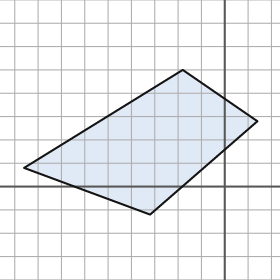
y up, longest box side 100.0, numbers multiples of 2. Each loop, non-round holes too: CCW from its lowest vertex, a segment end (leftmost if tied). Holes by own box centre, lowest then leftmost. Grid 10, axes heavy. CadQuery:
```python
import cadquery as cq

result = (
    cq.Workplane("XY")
    .moveTo(-32.0, -12.0)
    .lineTo(14.0, 28.0)
    .lineTo(-18.0, 50.0)
    .lineTo(-86.0, 8.0)
    .close()
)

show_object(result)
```